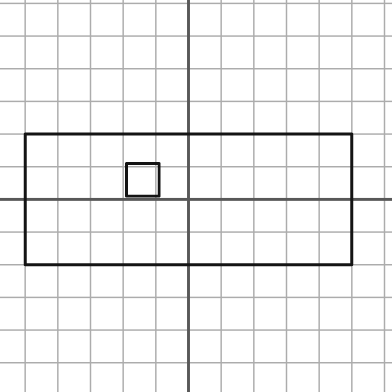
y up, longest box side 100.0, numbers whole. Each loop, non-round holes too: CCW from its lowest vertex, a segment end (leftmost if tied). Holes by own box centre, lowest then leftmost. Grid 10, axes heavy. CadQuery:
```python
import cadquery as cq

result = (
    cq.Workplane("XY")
    .moveTo(-50.0, -20.0)
    .lineTo(50.0, -20.0)
    .lineTo(50.0, 20.0)
    .lineTo(-50.0, 20.0)
    .close()
    .moveTo(-19.0, 1.0)
    .lineTo(-9.0, 1.0)
    .lineTo(-9.0, 11.0)
    .lineTo(-19.0, 11.0)
    .close()
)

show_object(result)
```